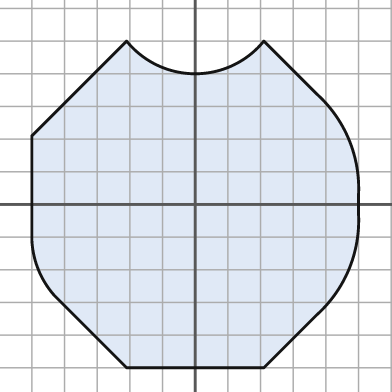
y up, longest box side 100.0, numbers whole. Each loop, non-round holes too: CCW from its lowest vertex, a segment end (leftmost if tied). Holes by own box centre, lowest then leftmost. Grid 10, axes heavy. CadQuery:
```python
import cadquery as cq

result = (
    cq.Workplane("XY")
    .moveTo(-21.0, -50.0)
    .lineTo(21.0, -50.0)
    .lineTo(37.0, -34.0)
    .threePointArc((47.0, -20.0), (50.0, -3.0))
    .lineTo(50.0, 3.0)
    .threePointArc((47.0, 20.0), (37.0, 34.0))
    .lineTo(21.0, 50.0)
    .threePointArc((0.0, 40.0), (-21.0, 50.0))
    .lineTo(-50.0, 21.0)
    .lineTo(-50.0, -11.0)
    .threePointArc((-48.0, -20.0), (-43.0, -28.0))
    .close()
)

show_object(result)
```